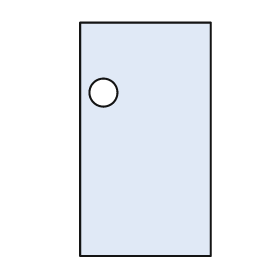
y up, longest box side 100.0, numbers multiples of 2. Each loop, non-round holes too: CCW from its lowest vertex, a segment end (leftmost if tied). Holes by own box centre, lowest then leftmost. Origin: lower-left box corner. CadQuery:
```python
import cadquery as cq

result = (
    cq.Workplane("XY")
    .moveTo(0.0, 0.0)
    .lineTo(56.0, 0.0)
    .lineTo(56.0, 100.0)
    .lineTo(0.0, 100.0)
    .close()
    .moveTo(10.0, 70.0)
    .circle(6.0)
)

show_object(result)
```